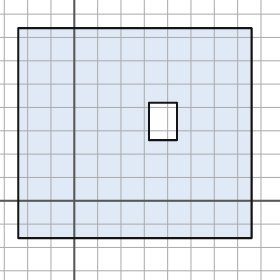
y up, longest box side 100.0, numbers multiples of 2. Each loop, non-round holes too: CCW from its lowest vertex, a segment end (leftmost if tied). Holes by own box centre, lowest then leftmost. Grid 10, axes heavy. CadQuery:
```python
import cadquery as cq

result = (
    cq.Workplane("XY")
    .moveTo(-24.0, -16.0)
    .lineTo(76.0, -16.0)
    .lineTo(76.0, 74.0)
    .lineTo(-24.0, 74.0)
    .close()
    .moveTo(32.0, 26.0)
    .lineTo(44.0, 26.0)
    .lineTo(44.0, 42.0)
    .lineTo(32.0, 42.0)
    .close()
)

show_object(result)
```